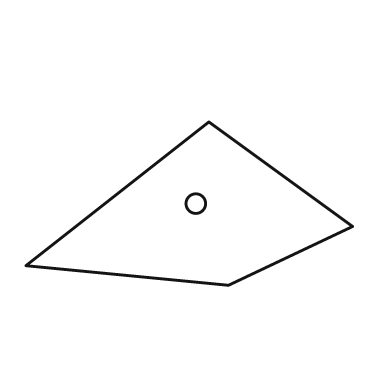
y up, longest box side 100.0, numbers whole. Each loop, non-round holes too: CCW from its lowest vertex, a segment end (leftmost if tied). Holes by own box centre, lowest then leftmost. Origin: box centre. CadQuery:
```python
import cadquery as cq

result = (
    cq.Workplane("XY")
    .moveTo(12.0, -25.0)
    .lineTo(50.0, -7.0)
    .lineTo(6.0, 25.0)
    .lineTo(-50.0, -19.0)
    .close()
    .moveTo(2.0, 0.0)
    .circle(3.0)
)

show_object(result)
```